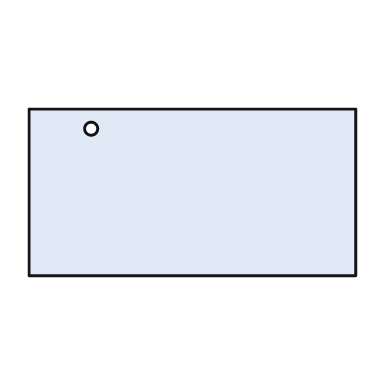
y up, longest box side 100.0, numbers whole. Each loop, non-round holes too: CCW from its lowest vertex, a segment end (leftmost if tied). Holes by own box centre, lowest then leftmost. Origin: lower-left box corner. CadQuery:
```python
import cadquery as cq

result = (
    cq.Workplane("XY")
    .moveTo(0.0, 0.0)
    .lineTo(100.0, 0.0)
    .lineTo(100.0, 51.0)
    .lineTo(0.0, 51.0)
    .close()
    .moveTo(19.0, 45.0)
    .circle(2.0)
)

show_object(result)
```